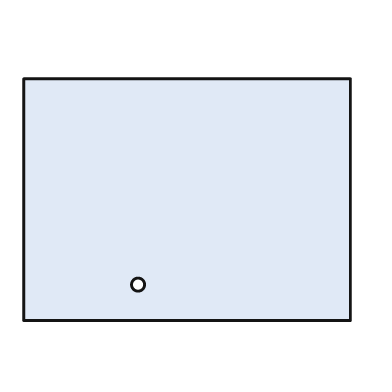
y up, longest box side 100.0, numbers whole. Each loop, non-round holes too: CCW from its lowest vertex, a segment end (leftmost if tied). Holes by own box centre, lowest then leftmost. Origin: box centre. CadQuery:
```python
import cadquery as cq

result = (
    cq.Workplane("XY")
    .moveTo(-50.0, -37.0)
    .lineTo(50.0, -37.0)
    .lineTo(50.0, 37.0)
    .lineTo(-50.0, 37.0)
    .close()
    .moveTo(-15.0, -26.0)
    .circle(2.0)
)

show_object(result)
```